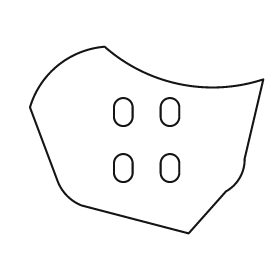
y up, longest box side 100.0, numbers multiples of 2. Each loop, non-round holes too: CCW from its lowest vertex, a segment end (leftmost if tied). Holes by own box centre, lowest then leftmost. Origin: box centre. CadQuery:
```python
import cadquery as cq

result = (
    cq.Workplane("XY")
    .moveTo(18.0, -40.0)
    .lineTo(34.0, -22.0)
    .threePointArc((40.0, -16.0), (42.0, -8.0))
    .lineTo(50.0, 26.0)
    .threePointArc((14.0, 24.0), (-18.0, 40.0))
    .threePointArc((-38.0, 32.0), (-50.0, 14.0))
    .lineTo(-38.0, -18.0)
    .threePointArc((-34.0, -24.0), (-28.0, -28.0))
    .close()
    .moveTo(-14.0, -14.0)
    .threePointArc((-10.0, -18.0), (-6.0, -14.0))
    .lineTo(-6.0, -10.0)
    .threePointArc((-10.0, -6.0), (-14.0, -10.0))
    .close()
    .moveTo(6.0, -14.0)
    .threePointArc((10.0, -18.0), (14.0, -14.0))
    .lineTo(14.0, -10.0)
    .threePointArc((10.0, -6.0), (6.0, -10.0))
    .close()
    .moveTo(-14.0, 10.0)
    .threePointArc((-10.0, 6.0), (-6.0, 10.0))
    .lineTo(-6.0, 14.0)
    .threePointArc((-10.0, 18.0), (-14.0, 14.0))
    .close()
    .moveTo(6.0, 10.0)
    .threePointArc((10.0, 6.0), (14.0, 10.0))
    .lineTo(14.0, 14.0)
    .threePointArc((10.0, 18.0), (6.0, 14.0))
    .close()
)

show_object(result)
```